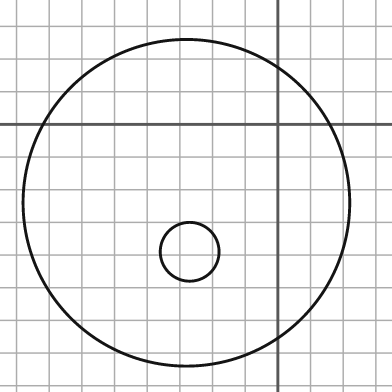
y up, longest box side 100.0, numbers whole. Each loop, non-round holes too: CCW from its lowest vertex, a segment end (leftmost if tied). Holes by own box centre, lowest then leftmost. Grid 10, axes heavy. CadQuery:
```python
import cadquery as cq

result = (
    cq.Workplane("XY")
    .moveTo(-28.0, -24.0)
    .circle(50.0)
    .moveTo(-27.0, -39.0)
    .circle(9.0)
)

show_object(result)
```